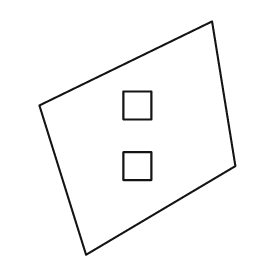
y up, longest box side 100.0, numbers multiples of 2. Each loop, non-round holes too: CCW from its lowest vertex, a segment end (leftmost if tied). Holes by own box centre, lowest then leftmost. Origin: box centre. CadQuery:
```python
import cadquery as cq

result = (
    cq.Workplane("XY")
    .moveTo(-22.0, -50.0)
    .lineTo(42.0, -12.0)
    .lineTo(32.0, 50.0)
    .lineTo(-42.0, 14.0)
    .close()
    .moveTo(-6.0, -18.0)
    .lineTo(6.0, -18.0)
    .lineTo(6.0, -6.0)
    .lineTo(-6.0, -6.0)
    .close()
    .moveTo(-6.0, 8.0)
    .lineTo(6.0, 8.0)
    .lineTo(6.0, 20.0)
    .lineTo(-6.0, 20.0)
    .close()
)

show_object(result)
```